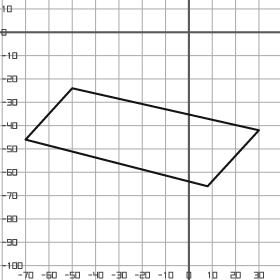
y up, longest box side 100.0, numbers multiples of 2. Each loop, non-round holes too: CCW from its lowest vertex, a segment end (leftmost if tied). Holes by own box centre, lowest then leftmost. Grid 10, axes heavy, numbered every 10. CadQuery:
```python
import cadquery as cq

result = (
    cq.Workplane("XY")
    .moveTo(8.0, -66.0)
    .lineTo(30.0, -42.0)
    .lineTo(-50.0, -24.0)
    .lineTo(-70.0, -46.0)
    .close()
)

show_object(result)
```